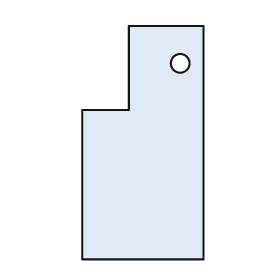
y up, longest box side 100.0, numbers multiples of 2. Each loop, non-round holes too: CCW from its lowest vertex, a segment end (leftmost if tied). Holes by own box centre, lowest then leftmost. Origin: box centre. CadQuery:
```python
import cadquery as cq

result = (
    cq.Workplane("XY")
    .moveTo(-26.0, -50.0)
    .lineTo(26.0, -50.0)
    .lineTo(26.0, 50.0)
    .lineTo(-6.0, 50.0)
    .lineTo(-6.0, 14.0)
    .lineTo(-26.0, 14.0)
    .close()
    .moveTo(16.0, 34.0)
    .circle(4.0)
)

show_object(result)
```